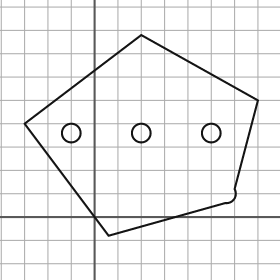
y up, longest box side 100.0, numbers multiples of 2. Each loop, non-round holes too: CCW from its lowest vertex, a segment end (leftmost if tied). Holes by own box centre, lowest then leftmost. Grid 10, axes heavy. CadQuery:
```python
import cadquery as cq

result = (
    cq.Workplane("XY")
    .moveTo(6.0, -8.0)
    .lineTo(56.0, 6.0)
    .threePointArc((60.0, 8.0), (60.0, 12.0))
    .lineTo(70.0, 50.0)
    .lineTo(20.0, 78.0)
    .lineTo(-30.0, 40.0)
    .close()
    .moveTo(-10.0, 36.0)
    .circle(4.0)
    .moveTo(20.0, 36.0)
    .circle(4.0)
    .moveTo(50.0, 36.0)
    .circle(4.0)
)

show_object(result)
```